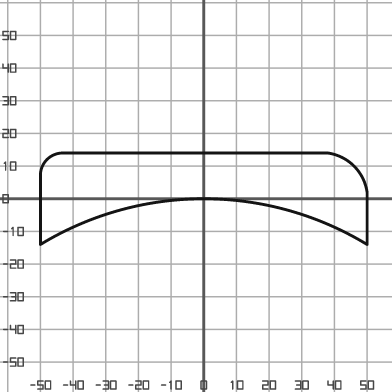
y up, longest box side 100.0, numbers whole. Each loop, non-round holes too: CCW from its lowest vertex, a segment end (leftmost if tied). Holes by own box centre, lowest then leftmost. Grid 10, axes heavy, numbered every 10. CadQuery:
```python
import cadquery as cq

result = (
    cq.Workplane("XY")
    .moveTo(-50.0, -14.0)
    .threePointArc((0.0, 0.0), (50.0, -14.0))
    .lineTo(50.0, 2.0)
    .threePointArc((46.0, 10.0), (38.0, 14.0))
    .lineTo(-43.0, 14.0)
    .threePointArc((-48.0, 12.0), (-50.0, 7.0))
    .close()
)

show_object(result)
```